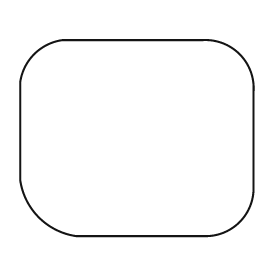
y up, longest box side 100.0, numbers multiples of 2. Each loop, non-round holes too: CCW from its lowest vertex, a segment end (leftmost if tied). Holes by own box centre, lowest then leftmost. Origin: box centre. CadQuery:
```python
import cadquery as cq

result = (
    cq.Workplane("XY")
    .moveTo(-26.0, -42.0)
    .lineTo(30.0, -42.0)
    .threePointArc((44.0, -36.0), (50.0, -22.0))
    .lineTo(50.0, 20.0)
    .threePointArc((44.0, 36.0), (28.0, 42.0))
    .lineTo(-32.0, 42.0)
    .threePointArc((-44.0, 36.0), (-50.0, 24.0))
    .lineTo(-50.0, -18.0)
    .threePointArc((-42.0, -34.0), (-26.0, -42.0))
    .close()
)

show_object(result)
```